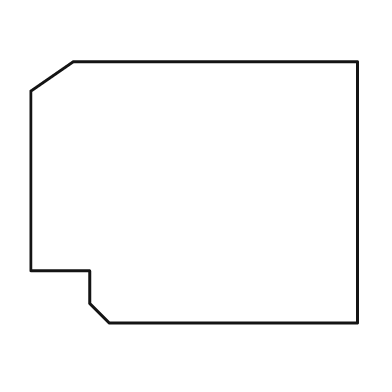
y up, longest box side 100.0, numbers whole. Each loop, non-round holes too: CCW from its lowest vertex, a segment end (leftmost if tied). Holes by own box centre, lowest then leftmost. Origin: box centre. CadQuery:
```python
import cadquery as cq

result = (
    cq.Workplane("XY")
    .moveTo(-26.0, -40.0)
    .lineTo(50.0, -40.0)
    .lineTo(50.0, 40.0)
    .lineTo(-37.0, 40.0)
    .lineTo(-50.0, 31.0)
    .lineTo(-50.0, -24.0)
    .lineTo(-32.0, -24.0)
    .lineTo(-32.0, -34.0)
    .close()
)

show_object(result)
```